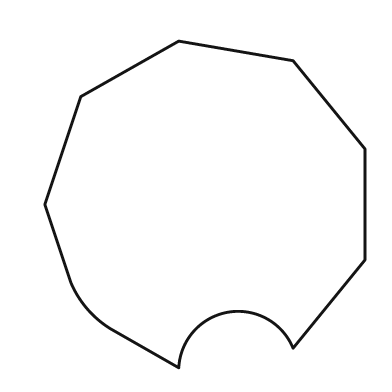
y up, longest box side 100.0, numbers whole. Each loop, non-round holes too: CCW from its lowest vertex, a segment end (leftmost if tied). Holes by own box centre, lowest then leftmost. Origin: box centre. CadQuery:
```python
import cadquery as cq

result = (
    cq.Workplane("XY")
    .moveTo(-8.0, -50.0)
    .threePointArc((7.0, -33.0), (27.0, -44.0))
    .lineTo(49.0, -17.0)
    .lineTo(49.0, 17.0)
    .lineTo(27.0, 44.0)
    .lineTo(-8.0, 50.0)
    .lineTo(-38.0, 33.0)
    .lineTo(-49.0, 0.0)
    .lineTo(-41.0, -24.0)
    .threePointArc((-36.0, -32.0), (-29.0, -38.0))
    .close()
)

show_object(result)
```